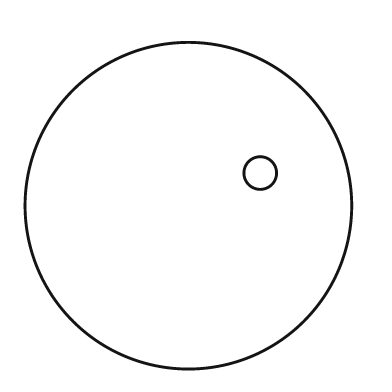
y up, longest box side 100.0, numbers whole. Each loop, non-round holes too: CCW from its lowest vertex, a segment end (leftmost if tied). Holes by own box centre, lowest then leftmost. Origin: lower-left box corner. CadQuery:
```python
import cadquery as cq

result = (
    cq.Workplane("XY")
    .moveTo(50.0, 50.0)
    .circle(50.0)
    .moveTo(72.0, 60.0)
    .circle(5.0)
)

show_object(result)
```